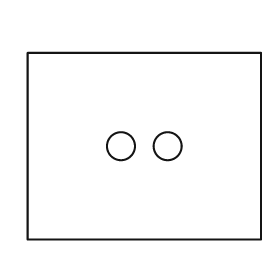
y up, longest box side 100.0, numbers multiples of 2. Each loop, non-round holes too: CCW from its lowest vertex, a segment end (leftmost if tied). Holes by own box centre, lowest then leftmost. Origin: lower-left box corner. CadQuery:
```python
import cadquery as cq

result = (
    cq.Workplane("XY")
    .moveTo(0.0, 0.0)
    .lineTo(100.0, 0.0)
    .lineTo(100.0, 80.0)
    .lineTo(0.0, 80.0)
    .close()
    .moveTo(40.0, 40.0)
    .circle(6.0)
    .moveTo(60.0, 40.0)
    .circle(6.0)
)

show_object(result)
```